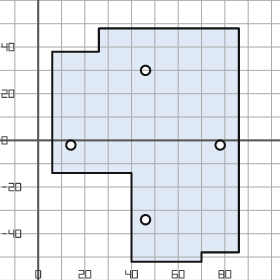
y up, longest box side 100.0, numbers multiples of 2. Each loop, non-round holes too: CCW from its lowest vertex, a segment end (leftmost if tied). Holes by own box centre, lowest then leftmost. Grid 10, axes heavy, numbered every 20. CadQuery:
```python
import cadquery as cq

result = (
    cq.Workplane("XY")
    .moveTo(40.0, -52.0)
    .lineTo(70.0, -52.0)
    .lineTo(70.0, -48.0)
    .lineTo(86.0, -48.0)
    .lineTo(86.0, 48.0)
    .lineTo(26.0, 48.0)
    .lineTo(26.0, 38.0)
    .lineTo(6.0, 38.0)
    .lineTo(6.0, -14.0)
    .lineTo(40.0, -14.0)
    .close()
    .moveTo(46.0, -34.0)
    .circle(2.0)
    .moveTo(14.0, -2.0)
    .circle(2.0)
    .moveTo(78.0, -2.0)
    .circle(2.0)
    .moveTo(46.0, 30.0)
    .circle(2.0)
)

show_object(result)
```